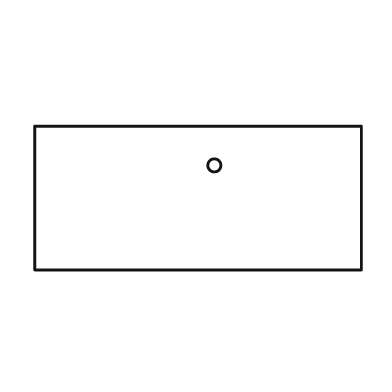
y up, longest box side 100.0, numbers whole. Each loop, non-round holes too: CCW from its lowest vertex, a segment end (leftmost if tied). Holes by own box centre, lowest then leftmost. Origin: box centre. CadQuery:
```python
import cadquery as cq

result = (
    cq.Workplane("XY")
    .moveTo(-50.0, -22.0)
    .lineTo(50.0, -22.0)
    .lineTo(50.0, 22.0)
    .lineTo(-50.0, 22.0)
    .close()
    .moveTo(5.0, 10.0)
    .circle(2.0)
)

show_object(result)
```